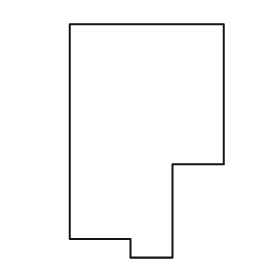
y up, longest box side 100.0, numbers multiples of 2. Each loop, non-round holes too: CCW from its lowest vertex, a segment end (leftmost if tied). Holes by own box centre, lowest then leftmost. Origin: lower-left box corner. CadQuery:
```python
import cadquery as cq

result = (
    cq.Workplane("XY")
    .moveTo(26.0, 0.0)
    .lineTo(44.0, 0.0)
    .lineTo(44.0, 40.0)
    .lineTo(66.0, 40.0)
    .lineTo(66.0, 100.0)
    .lineTo(0.0, 100.0)
    .lineTo(0.0, 8.0)
    .lineTo(26.0, 8.0)
    .close()
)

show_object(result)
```